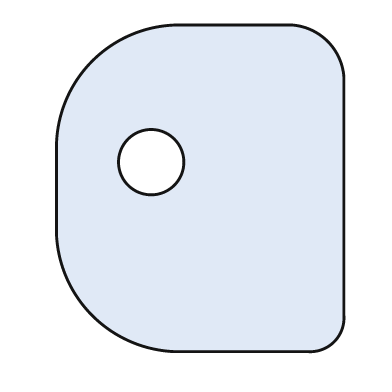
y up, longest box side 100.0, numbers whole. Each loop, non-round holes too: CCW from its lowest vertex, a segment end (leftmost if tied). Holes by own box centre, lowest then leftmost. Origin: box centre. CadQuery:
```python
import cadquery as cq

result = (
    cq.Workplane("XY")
    .moveTo(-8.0, -50.0)
    .lineTo(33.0, -50.0)
    .threePointArc((41.0, -47.0), (44.0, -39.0))
    .lineTo(44.0, 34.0)
    .threePointArc((39.0, 45.0), (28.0, 50.0))
    .lineTo(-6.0, 50.0)
    .threePointArc((-33.0, 39.0), (-44.0, 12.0))
    .lineTo(-44.0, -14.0)
    .threePointArc((-33.0, -39.0), (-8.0, -50.0))
    .close()
    .moveTo(-15.0, 8.0)
    .circle(10.0)
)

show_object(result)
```